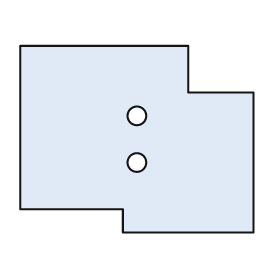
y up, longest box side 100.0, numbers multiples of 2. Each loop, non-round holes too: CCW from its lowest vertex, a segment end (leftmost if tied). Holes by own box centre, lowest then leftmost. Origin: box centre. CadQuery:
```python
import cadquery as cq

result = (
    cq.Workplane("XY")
    .moveTo(-6.0, -40.0)
    .lineTo(50.0, -40.0)
    .lineTo(50.0, 20.0)
    .lineTo(22.0, 20.0)
    .lineTo(22.0, 40.0)
    .lineTo(-50.0, 40.0)
    .lineTo(-50.0, -30.0)
    .lineTo(-6.0, -30.0)
    .close()
    .moveTo(0.0, -10.0)
    .circle(4.0)
    .moveTo(0.0, 10.0)
    .circle(4.0)
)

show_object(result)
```